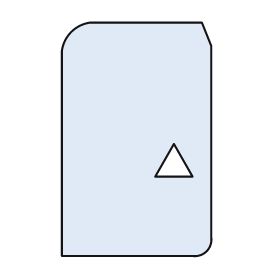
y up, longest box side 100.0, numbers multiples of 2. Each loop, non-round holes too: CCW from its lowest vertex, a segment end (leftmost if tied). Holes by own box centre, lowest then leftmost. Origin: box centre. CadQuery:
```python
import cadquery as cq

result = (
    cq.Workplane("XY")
    .moveTo(-32.0, -50.0)
    .lineTo(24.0, -50.0)
    .threePointArc((30.0, -48.0), (32.0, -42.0))
    .lineTo(32.0, 40.0)
    .lineTo(28.0, 50.0)
    .lineTo(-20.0, 50.0)
    .threePointArc((-28.0, 46.0), (-32.0, 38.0))
    .close()
    .moveTo(8.0, -16.0)
    .lineTo(24.0, -16.0)
    .lineTo(16.0, -2.0)
    .close()
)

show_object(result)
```